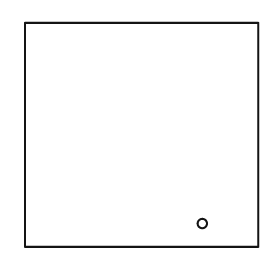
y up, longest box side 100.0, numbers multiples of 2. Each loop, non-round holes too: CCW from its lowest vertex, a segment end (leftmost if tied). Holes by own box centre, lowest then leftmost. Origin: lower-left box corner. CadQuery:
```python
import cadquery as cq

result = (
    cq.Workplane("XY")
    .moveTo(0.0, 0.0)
    .lineTo(100.0, 0.0)
    .lineTo(100.0, 96.0)
    .lineTo(0.0, 96.0)
    .close()
    .moveTo(76.0, 10.0)
    .circle(2.0)
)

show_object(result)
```